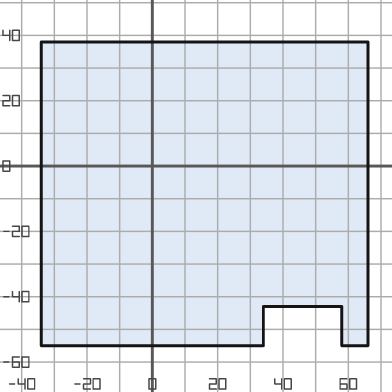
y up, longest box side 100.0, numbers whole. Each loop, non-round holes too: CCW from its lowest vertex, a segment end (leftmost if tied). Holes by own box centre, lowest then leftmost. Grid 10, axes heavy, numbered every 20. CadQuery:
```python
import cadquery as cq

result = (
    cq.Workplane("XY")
    .moveTo(-34.0, -55.0)
    .lineTo(34.0, -55.0)
    .lineTo(34.0, -43.0)
    .lineTo(58.0, -43.0)
    .lineTo(58.0, -55.0)
    .lineTo(66.0, -55.0)
    .lineTo(66.0, 38.0)
    .lineTo(-34.0, 38.0)
    .close()
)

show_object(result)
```